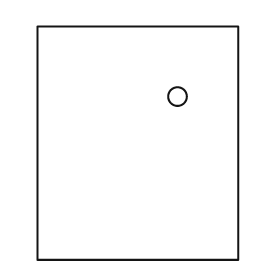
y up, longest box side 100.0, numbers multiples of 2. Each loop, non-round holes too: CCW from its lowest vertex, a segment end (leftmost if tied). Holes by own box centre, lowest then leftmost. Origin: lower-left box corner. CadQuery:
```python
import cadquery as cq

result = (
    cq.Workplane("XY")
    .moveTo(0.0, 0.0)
    .lineTo(86.0, 0.0)
    .lineTo(86.0, 100.0)
    .lineTo(0.0, 100.0)
    .close()
    .moveTo(60.0, 70.0)
    .circle(4.0)
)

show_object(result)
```